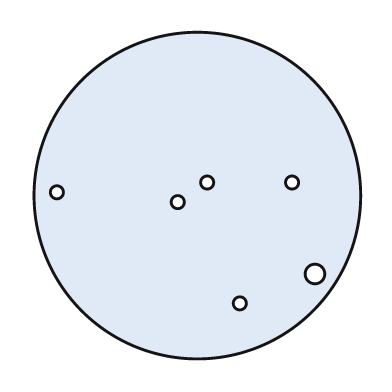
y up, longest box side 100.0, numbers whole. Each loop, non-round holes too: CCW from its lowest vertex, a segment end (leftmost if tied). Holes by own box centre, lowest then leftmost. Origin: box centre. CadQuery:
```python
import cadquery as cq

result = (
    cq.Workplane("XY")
    .moveTo(0.0, 0.0)
    .circle(50.0)
    .moveTo(13.0, -33.0)
    .circle(2.0)
    .moveTo(36.0, -24.0)
    .circle(3.0)
    .moveTo(-6.0, -2.0)
    .circle(2.0)
    .moveTo(-43.0, 1.0)
    .circle(2.0)
    .moveTo(3.0, 4.0)
    .circle(2.0)
    .moveTo(29.0, 4.0)
    .circle(2.0)
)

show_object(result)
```